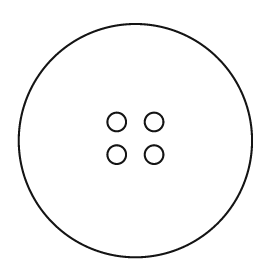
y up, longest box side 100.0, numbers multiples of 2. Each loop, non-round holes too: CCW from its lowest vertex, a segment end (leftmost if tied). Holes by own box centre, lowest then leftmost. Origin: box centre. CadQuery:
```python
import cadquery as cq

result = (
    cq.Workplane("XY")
    .moveTo(0.0, 0.0)
    .circle(50.0)
    .moveTo(-8.0, -6.0)
    .circle(4.0)
    .moveTo(8.0, -6.0)
    .circle(4.0)
    .moveTo(-8.0, 8.0)
    .circle(4.0)
    .moveTo(8.0, 8.0)
    .circle(4.0)
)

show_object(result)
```